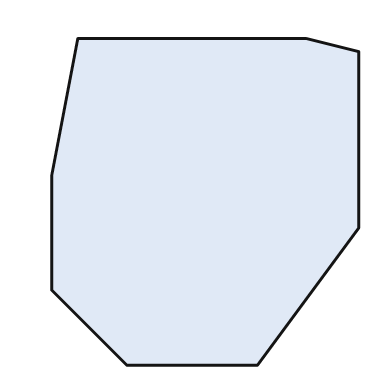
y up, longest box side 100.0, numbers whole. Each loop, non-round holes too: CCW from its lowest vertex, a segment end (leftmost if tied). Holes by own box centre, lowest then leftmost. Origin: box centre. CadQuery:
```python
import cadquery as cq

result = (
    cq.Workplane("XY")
    .moveTo(-24.0, -50.0)
    .lineTo(16.0, -50.0)
    .lineTo(47.0, -8.0)
    .lineTo(47.0, 46.0)
    .lineTo(31.0, 50.0)
    .lineTo(-39.0, 50.0)
    .lineTo(-47.0, 8.0)
    .lineTo(-47.0, -27.0)
    .close()
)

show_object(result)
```